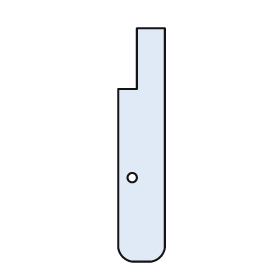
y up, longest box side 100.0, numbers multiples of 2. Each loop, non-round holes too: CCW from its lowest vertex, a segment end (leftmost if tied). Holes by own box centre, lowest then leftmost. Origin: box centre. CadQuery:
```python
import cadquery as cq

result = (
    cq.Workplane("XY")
    .moveTo(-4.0, -50.0)
    .lineTo(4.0, -50.0)
    .threePointArc((8.0, -48.0), (10.0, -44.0))
    .lineTo(10.0, 50.0)
    .lineTo(-2.0, 50.0)
    .lineTo(-2.0, 24.0)
    .lineTo(-10.0, 24.0)
    .lineTo(-10.0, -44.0)
    .threePointArc((-8.0, -48.0), (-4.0, -50.0))
    .close()
    .moveTo(-4.0, -14.0)
    .circle(2.0)
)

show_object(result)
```